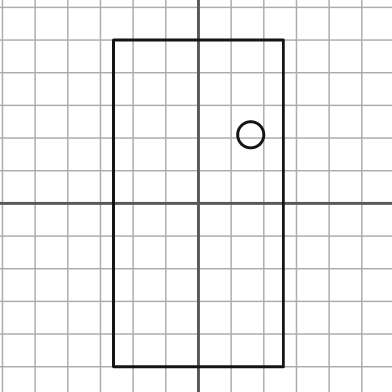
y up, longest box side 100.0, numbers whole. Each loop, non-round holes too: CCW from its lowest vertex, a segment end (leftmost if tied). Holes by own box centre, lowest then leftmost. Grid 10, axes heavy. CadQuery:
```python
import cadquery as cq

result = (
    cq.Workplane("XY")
    .moveTo(-26.0, -50.0)
    .lineTo(26.0, -50.0)
    .lineTo(26.0, 50.0)
    .lineTo(-26.0, 50.0)
    .close()
    .moveTo(16.0, 21.0)
    .circle(4.0)
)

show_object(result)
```